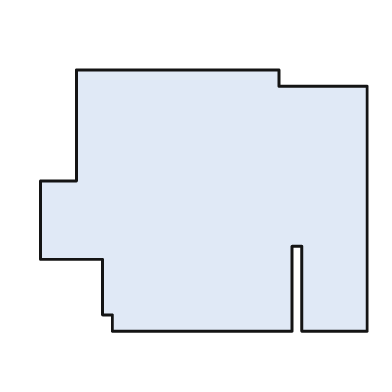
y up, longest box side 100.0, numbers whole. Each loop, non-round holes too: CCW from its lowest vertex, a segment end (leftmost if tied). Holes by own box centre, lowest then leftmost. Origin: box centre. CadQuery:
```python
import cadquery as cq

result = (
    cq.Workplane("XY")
    .moveTo(-28.0, -40.0)
    .lineTo(27.0, -40.0)
    .lineTo(27.0, -14.0)
    .lineTo(30.0, -14.0)
    .lineTo(30.0, -40.0)
    .lineTo(50.0, -40.0)
    .lineTo(50.0, 35.0)
    .lineTo(23.0, 35.0)
    .lineTo(23.0, 40.0)
    .lineTo(-39.0, 40.0)
    .lineTo(-39.0, 6.0)
    .lineTo(-50.0, 6.0)
    .lineTo(-50.0, -18.0)
    .lineTo(-31.0, -18.0)
    .lineTo(-31.0, -35.0)
    .lineTo(-28.0, -35.0)
    .close()
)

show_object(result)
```